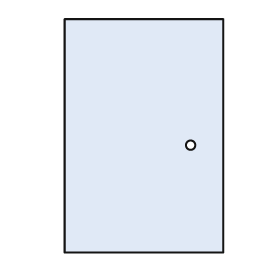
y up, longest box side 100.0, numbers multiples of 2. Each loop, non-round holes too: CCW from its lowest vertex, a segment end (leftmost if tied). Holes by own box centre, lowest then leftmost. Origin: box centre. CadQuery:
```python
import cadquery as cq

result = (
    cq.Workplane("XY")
    .moveTo(-34.0, -50.0)
    .lineTo(34.0, -50.0)
    .lineTo(34.0, 50.0)
    .lineTo(-34.0, 50.0)
    .close()
    .moveTo(20.0, -4.0)
    .circle(2.0)
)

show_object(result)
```